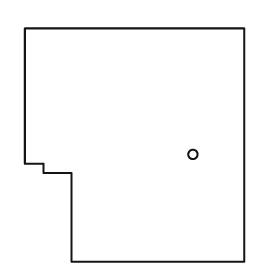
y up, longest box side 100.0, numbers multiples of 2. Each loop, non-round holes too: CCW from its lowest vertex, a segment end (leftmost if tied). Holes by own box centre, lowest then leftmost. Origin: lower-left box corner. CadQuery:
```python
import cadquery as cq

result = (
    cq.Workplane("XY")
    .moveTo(20.0, 0.0)
    .lineTo(94.0, 0.0)
    .lineTo(94.0, 100.0)
    .lineTo(0.0, 100.0)
    .lineTo(0.0, 42.0)
    .lineTo(8.0, 42.0)
    .lineTo(8.0, 38.0)
    .lineTo(20.0, 38.0)
    .close()
    .moveTo(72.0, 46.0)
    .circle(2.0)
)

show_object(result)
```